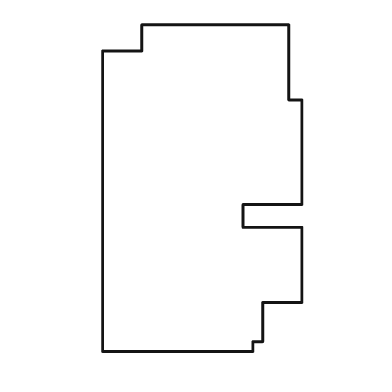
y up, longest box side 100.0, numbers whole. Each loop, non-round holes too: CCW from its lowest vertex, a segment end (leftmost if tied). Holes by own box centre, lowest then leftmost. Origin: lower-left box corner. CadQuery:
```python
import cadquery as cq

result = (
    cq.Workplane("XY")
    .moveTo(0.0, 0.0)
    .lineTo(46.0, 0.0)
    .lineTo(46.0, 3.0)
    .lineTo(49.0, 3.0)
    .lineTo(49.0, 15.0)
    .lineTo(61.0, 15.0)
    .lineTo(61.0, 38.0)
    .lineTo(43.0, 38.0)
    .lineTo(43.0, 45.0)
    .lineTo(61.0, 45.0)
    .lineTo(61.0, 77.0)
    .lineTo(57.0, 77.0)
    .lineTo(57.0, 100.0)
    .lineTo(12.0, 100.0)
    .lineTo(12.0, 92.0)
    .lineTo(0.0, 92.0)
    .close()
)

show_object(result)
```